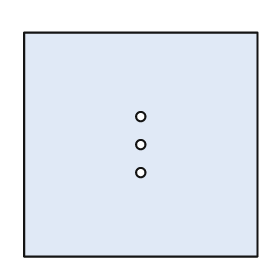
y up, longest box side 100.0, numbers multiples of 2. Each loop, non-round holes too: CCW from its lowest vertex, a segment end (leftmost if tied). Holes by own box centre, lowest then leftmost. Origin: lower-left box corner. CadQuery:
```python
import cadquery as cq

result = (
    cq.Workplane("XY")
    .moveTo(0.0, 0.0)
    .lineTo(100.0, 0.0)
    .lineTo(100.0, 96.0)
    .lineTo(0.0, 96.0)
    .close()
    .moveTo(50.0, 36.0)
    .circle(2.0)
    .moveTo(50.0, 48.0)
    .circle(2.0)
    .moveTo(50.0, 60.0)
    .circle(2.0)
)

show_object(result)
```